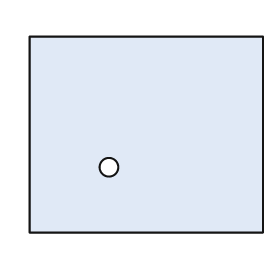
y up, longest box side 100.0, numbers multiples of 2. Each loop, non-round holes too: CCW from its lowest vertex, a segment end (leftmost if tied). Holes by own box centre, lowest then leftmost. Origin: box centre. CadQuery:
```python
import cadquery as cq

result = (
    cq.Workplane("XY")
    .moveTo(-50.0, -42.0)
    .lineTo(50.0, -42.0)
    .lineTo(50.0, 42.0)
    .lineTo(-50.0, 42.0)
    .close()
    .moveTo(-16.0, -14.0)
    .circle(4.0)
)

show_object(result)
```